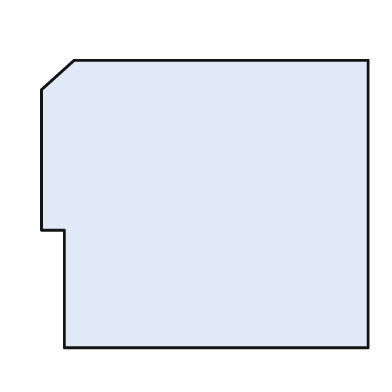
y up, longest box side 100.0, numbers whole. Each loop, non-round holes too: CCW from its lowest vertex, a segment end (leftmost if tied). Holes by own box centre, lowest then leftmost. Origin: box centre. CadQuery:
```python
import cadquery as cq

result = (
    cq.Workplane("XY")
    .moveTo(-43.0, -44.0)
    .lineTo(50.0, -44.0)
    .lineTo(50.0, 44.0)
    .lineTo(-40.0, 44.0)
    .lineTo(-50.0, 35.0)
    .lineTo(-50.0, -8.0)
    .lineTo(-43.0, -8.0)
    .close()
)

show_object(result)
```